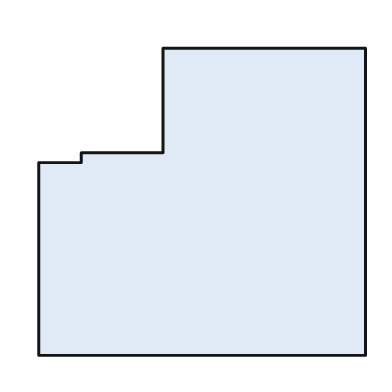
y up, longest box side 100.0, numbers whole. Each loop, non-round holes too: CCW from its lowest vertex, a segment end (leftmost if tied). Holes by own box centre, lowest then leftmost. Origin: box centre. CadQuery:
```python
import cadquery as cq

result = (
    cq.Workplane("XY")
    .moveTo(-50.0, -47.0)
    .lineTo(50.0, -47.0)
    .lineTo(50.0, 47.0)
    .lineTo(-12.0, 47.0)
    .lineTo(-12.0, 15.0)
    .lineTo(-37.0, 15.0)
    .lineTo(-37.0, 12.0)
    .lineTo(-50.0, 12.0)
    .close()
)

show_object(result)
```